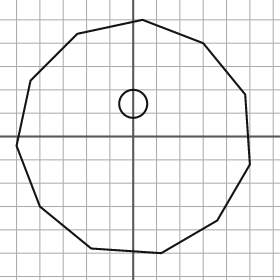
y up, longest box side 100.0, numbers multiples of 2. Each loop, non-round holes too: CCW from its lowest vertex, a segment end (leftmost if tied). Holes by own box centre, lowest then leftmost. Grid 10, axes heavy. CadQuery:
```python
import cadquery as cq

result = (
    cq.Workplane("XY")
    .moveTo(12.0, -50.0)
    .lineTo(36.0, -36.0)
    .lineTo(50.0, -12.0)
    .lineTo(48.0, 18.0)
    .lineTo(30.0, 40.0)
    .lineTo(4.0, 50.0)
    .lineTo(-24.0, 44.0)
    .lineTo(-44.0, 24.0)
    .lineTo(-50.0, -4.0)
    .lineTo(-40.0, -30.0)
    .lineTo(-18.0, -48.0)
    .close()
    .moveTo(0.0, 14.0)
    .circle(6.0)
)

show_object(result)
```